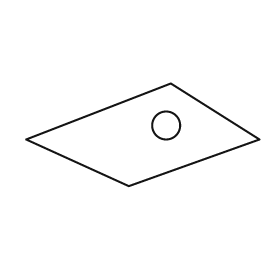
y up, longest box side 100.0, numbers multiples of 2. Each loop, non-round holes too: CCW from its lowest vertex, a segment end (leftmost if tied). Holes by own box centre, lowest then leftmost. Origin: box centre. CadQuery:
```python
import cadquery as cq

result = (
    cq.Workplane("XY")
    .moveTo(-6.0, -22.0)
    .lineTo(50.0, -2.0)
    .lineTo(12.0, 22.0)
    .lineTo(-50.0, -2.0)
    .close()
    .moveTo(10.0, 4.0)
    .circle(6.0)
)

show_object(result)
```